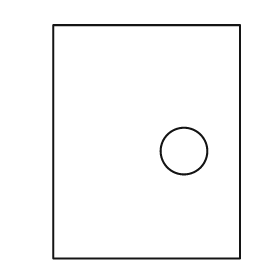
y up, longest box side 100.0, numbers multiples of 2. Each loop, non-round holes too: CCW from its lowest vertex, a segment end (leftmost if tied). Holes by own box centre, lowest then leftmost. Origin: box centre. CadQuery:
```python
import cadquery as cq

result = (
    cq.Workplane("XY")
    .moveTo(-40.0, -50.0)
    .lineTo(40.0, -50.0)
    .lineTo(40.0, 50.0)
    .lineTo(-40.0, 50.0)
    .close()
    .moveTo(16.0, -4.0)
    .circle(10.0)
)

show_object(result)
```